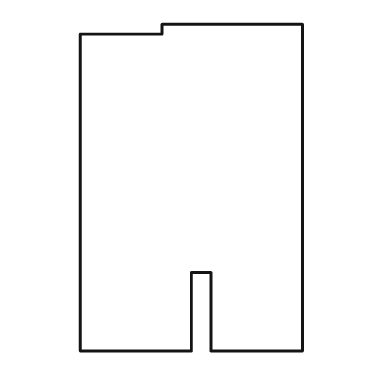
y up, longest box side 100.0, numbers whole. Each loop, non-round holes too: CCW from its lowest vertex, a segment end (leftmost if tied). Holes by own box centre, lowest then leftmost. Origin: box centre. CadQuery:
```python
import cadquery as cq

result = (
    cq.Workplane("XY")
    .moveTo(-34.0, -50.0)
    .lineTo(0.0, -50.0)
    .lineTo(0.0, -26.0)
    .lineTo(6.0, -26.0)
    .lineTo(6.0, -50.0)
    .lineTo(34.0, -50.0)
    .lineTo(34.0, 50.0)
    .lineTo(-9.0, 50.0)
    .lineTo(-9.0, 47.0)
    .lineTo(-34.0, 47.0)
    .close()
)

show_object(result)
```